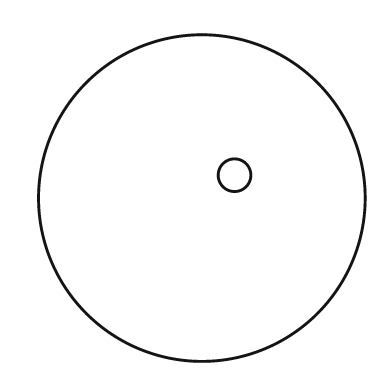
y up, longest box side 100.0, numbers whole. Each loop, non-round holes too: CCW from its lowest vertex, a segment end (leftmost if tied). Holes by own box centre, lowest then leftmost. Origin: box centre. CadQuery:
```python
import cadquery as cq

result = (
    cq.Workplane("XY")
    .moveTo(0.0, 0.0)
    .circle(50.0)
    .moveTo(10.0, 7.0)
    .circle(5.0)
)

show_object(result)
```